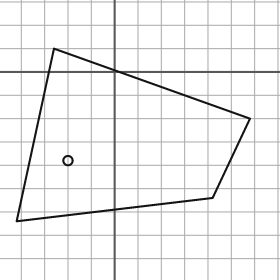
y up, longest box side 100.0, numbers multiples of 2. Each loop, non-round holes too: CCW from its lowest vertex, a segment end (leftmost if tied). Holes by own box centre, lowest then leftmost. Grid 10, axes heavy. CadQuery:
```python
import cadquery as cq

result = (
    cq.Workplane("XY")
    .moveTo(-42.0, -64.0)
    .lineTo(42.0, -54.0)
    .lineTo(58.0, -20.0)
    .lineTo(-26.0, 10.0)
    .close()
    .moveTo(-20.0, -38.0)
    .circle(2.0)
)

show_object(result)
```